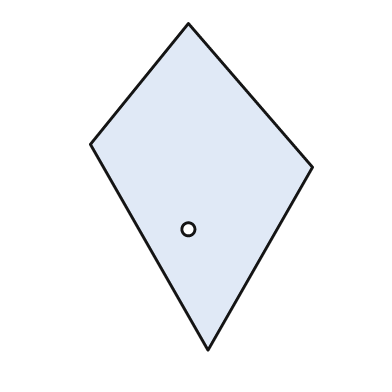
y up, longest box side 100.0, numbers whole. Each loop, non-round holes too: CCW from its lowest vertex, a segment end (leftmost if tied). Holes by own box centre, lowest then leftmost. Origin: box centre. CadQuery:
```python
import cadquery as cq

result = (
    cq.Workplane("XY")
    .moveTo(2.0, -50.0)
    .lineTo(34.0, 6.0)
    .lineTo(-4.0, 50.0)
    .lineTo(-34.0, 13.0)
    .close()
    .moveTo(-4.0, -13.0)
    .circle(2.0)
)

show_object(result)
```